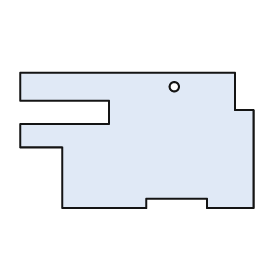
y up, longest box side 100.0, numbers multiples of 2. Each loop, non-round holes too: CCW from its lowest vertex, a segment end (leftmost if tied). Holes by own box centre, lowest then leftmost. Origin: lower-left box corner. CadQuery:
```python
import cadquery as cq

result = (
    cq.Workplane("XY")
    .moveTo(18.0, 0.0)
    .lineTo(54.0, 0.0)
    .lineTo(54.0, 4.0)
    .lineTo(80.0, 4.0)
    .lineTo(80.0, 0.0)
    .lineTo(100.0, 0.0)
    .lineTo(100.0, 42.0)
    .lineTo(92.0, 42.0)
    .lineTo(92.0, 58.0)
    .lineTo(0.0, 58.0)
    .lineTo(0.0, 46.0)
    .lineTo(38.0, 46.0)
    .lineTo(38.0, 36.0)
    .lineTo(0.0, 36.0)
    .lineTo(0.0, 26.0)
    .lineTo(18.0, 26.0)
    .close()
    .moveTo(66.0, 52.0)
    .circle(2.0)
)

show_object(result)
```